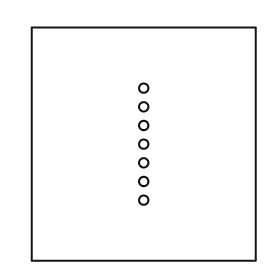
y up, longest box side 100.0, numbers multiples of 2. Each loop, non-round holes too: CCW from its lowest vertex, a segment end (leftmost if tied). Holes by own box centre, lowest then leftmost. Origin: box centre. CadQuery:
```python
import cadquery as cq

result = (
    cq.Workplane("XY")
    .moveTo(-48.0, -50.0)
    .lineTo(48.0, -50.0)
    .lineTo(48.0, 50.0)
    .lineTo(-48.0, 50.0)
    .close()
    .moveTo(0.0, -24.0)
    .circle(2.0)
    .moveTo(0.0, -16.0)
    .circle(2.0)
    .moveTo(0.0, -8.0)
    .circle(2.0)
    .moveTo(0.0, 0.0)
    .circle(2.0)
    .moveTo(0.0, 8.0)
    .circle(2.0)
    .moveTo(0.0, 16.0)
    .circle(2.0)
    .moveTo(0.0, 24.0)
    .circle(2.0)
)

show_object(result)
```